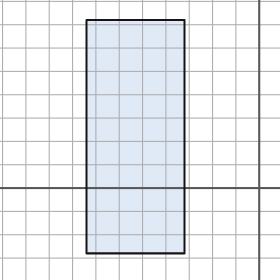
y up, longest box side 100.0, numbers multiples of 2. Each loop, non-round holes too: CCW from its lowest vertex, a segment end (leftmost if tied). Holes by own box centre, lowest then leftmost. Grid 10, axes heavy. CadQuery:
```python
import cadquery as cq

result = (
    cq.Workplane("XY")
    .moveTo(-74.0, -28.0)
    .lineTo(-32.0, -28.0)
    .lineTo(-32.0, 72.0)
    .lineTo(-74.0, 72.0)
    .close()
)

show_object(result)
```